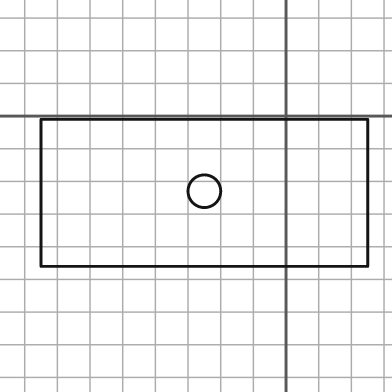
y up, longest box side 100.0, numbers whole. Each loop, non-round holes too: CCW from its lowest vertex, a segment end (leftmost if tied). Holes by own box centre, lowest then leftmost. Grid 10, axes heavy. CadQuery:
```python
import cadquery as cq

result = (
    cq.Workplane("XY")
    .moveTo(-75.0, -46.0)
    .lineTo(25.0, -46.0)
    .lineTo(25.0, -1.0)
    .lineTo(-75.0, -1.0)
    .close()
    .moveTo(-25.0, -23.0)
    .circle(5.0)
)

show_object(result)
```